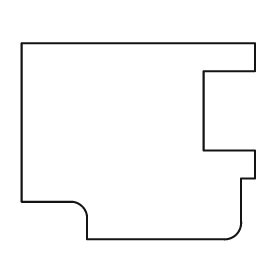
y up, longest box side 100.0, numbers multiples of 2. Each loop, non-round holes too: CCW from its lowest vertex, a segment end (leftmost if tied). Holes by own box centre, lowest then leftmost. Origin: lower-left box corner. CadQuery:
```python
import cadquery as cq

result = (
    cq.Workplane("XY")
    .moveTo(28.0, 0.0)
    .lineTo(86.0, 0.0)
    .threePointArc((92.0, 2.0), (94.0, 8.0))
    .lineTo(94.0, 26.0)
    .lineTo(100.0, 26.0)
    .lineTo(100.0, 38.0)
    .lineTo(78.0, 38.0)
    .lineTo(78.0, 72.0)
    .lineTo(100.0, 72.0)
    .lineTo(100.0, 84.0)
    .lineTo(0.0, 84.0)
    .lineTo(0.0, 16.0)
    .lineTo(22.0, 16.0)
    .threePointArc((26.0, 14.0), (28.0, 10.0))
    .close()
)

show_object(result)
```